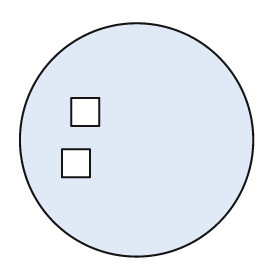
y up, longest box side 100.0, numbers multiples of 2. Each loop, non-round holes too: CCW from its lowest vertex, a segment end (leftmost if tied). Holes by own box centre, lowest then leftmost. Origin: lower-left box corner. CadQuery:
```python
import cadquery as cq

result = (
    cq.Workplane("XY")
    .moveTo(50.0, 50.0)
    .circle(50.0)
    .moveTo(18.0, 34.0)
    .lineTo(30.0, 34.0)
    .lineTo(30.0, 46.0)
    .lineTo(18.0, 46.0)
    .close()
    .moveTo(22.0, 56.0)
    .lineTo(34.0, 56.0)
    .lineTo(34.0, 68.0)
    .lineTo(22.0, 68.0)
    .close()
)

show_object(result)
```